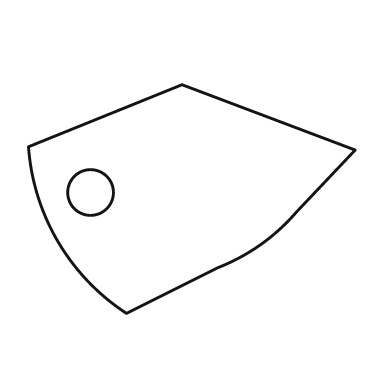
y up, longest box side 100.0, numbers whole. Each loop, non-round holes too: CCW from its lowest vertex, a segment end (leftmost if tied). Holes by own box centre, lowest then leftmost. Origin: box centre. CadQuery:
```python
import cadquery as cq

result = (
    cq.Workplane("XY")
    .moveTo(-20.0, -35.0)
    .lineTo(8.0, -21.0)
    .threePointArc((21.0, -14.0), (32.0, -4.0))
    .lineTo(50.0, 15.0)
    .lineTo(-3.0, 35.0)
    .lineTo(-50.0, 16.0)
    .threePointArc((-41.0, -13.0), (-20.0, -35.0))
    .close()
    .moveTo(-31.0, 2.0)
    .circle(7.0)
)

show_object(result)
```